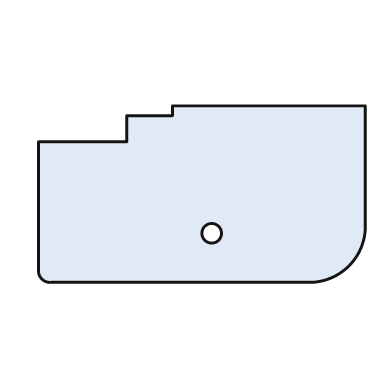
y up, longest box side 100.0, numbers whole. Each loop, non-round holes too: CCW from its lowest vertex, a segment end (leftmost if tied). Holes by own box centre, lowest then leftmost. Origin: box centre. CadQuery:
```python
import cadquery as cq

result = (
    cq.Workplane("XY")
    .moveTo(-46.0, -27.0)
    .lineTo(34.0, -27.0)
    .threePointArc((45.0, -22.0), (50.0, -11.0))
    .lineTo(50.0, 27.0)
    .lineTo(-9.0, 27.0)
    .lineTo(-9.0, 24.0)
    .lineTo(-23.0, 24.0)
    .lineTo(-23.0, 16.0)
    .lineTo(-50.0, 16.0)
    .lineTo(-50.0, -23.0)
    .threePointArc((-49.0, -26.0), (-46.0, -27.0))
    .close()
    .moveTo(3.0, -12.0)
    .circle(3.0)
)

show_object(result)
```